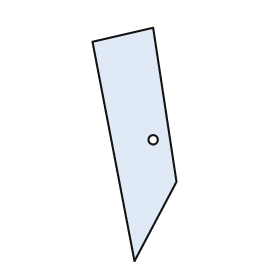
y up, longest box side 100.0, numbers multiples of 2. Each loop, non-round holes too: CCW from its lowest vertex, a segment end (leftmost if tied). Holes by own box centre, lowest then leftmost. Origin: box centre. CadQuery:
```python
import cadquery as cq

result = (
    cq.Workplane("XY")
    .moveTo(0.0, -50.0)
    .lineTo(18.0, -16.0)
    .lineTo(8.0, 50.0)
    .lineTo(-18.0, 44.0)
    .close()
    .moveTo(8.0, 2.0)
    .circle(2.0)
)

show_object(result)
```